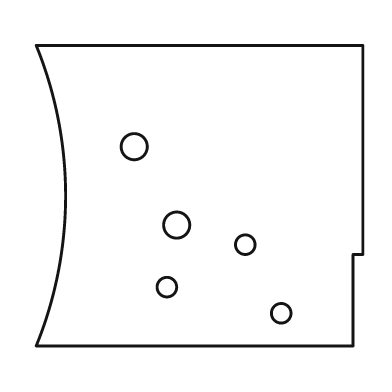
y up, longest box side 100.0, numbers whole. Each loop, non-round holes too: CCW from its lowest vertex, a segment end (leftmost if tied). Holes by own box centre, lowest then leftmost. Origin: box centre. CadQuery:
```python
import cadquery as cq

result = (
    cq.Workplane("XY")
    .moveTo(-50.0, -46.0)
    .lineTo(47.0, -46.0)
    .lineTo(47.0, -18.0)
    .lineTo(50.0, -18.0)
    .lineTo(50.0, 46.0)
    .lineTo(-50.0, 46.0)
    .threePointArc((-41.0, 0.0), (-50.0, -46.0))
    .close()
    .moveTo(25.0, -36.0)
    .circle(3.0)
    .moveTo(-10.0, -28.0)
    .circle(3.0)
    .moveTo(14.0, -15.0)
    .circle(3.0)
    .moveTo(-7.0, -9.0)
    .circle(4.0)
    .moveTo(-20.0, 15.0)
    .circle(4.0)
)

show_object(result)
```